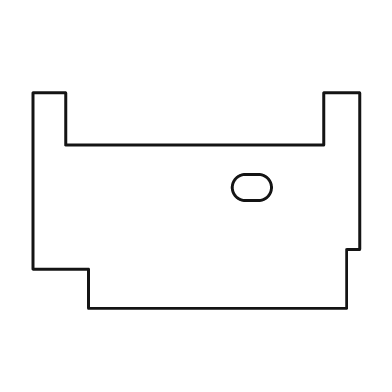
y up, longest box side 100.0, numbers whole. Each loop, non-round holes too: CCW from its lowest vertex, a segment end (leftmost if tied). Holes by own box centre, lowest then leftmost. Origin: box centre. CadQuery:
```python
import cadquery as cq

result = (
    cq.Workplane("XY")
    .moveTo(-33.0, -33.0)
    .lineTo(46.0, -33.0)
    .lineTo(46.0, -15.0)
    .lineTo(50.0, -15.0)
    .lineTo(50.0, 33.0)
    .lineTo(39.0, 33.0)
    .lineTo(39.0, 17.0)
    .lineTo(-40.0, 17.0)
    .lineTo(-40.0, 33.0)
    .lineTo(-50.0, 33.0)
    .lineTo(-50.0, -21.0)
    .lineTo(-33.0, -21.0)
    .close()
    .moveTo(15.0, 0.0)
    .lineTo(19.0, 0.0)
    .threePointArc((23.0, 4.0), (19.0, 8.0))
    .lineTo(15.0, 8.0)
    .threePointArc((11.0, 4.0), (15.0, 0.0))
    .close()
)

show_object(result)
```